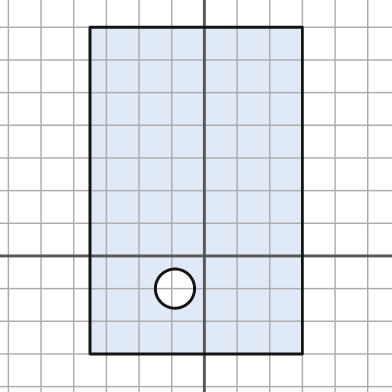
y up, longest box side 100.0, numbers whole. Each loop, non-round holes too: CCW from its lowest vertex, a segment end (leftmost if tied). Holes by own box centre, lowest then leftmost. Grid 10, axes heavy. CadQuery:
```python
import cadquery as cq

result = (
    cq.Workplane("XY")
    .moveTo(-35.0, -30.0)
    .lineTo(30.0, -30.0)
    .lineTo(30.0, 70.0)
    .lineTo(-35.0, 70.0)
    .close()
    .moveTo(-9.0, -10.0)
    .circle(6.0)
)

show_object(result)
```